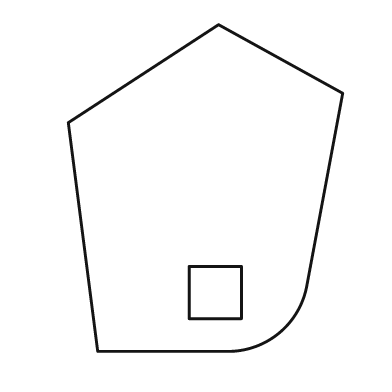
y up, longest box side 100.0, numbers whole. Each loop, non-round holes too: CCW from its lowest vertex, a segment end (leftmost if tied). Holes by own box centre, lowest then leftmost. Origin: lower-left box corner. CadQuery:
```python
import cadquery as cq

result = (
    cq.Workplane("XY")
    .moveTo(9.0, 0.0)
    .lineTo(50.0, 0.0)
    .threePointArc((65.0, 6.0), (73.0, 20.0))
    .lineTo(84.0, 79.0)
    .lineTo(46.0, 100.0)
    .lineTo(0.0, 70.0)
    .close()
    .moveTo(37.0, 10.0)
    .lineTo(53.0, 10.0)
    .lineTo(53.0, 26.0)
    .lineTo(37.0, 26.0)
    .close()
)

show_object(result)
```